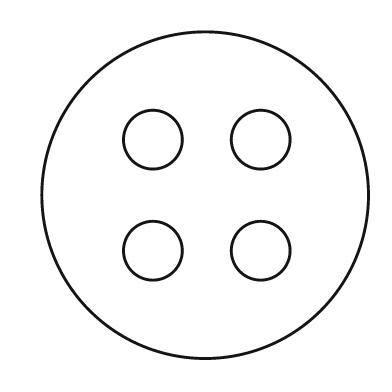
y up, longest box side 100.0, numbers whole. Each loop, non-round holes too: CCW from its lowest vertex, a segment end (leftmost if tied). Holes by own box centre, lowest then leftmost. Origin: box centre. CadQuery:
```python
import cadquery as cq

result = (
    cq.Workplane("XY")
    .moveTo(0.0, 0.0)
    .circle(50.0)
    .moveTo(-16.0, -17.0)
    .circle(9.0)
    .moveTo(17.0, -17.0)
    .circle(9.0)
    .moveTo(-16.0, 17.0)
    .circle(9.0)
    .moveTo(17.0, 17.0)
    .circle(9.0)
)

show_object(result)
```